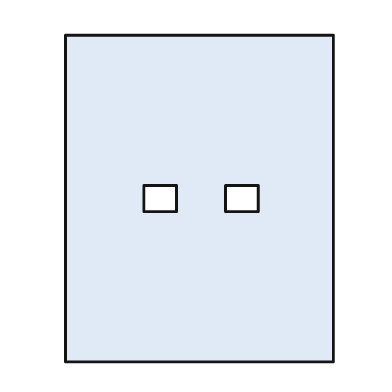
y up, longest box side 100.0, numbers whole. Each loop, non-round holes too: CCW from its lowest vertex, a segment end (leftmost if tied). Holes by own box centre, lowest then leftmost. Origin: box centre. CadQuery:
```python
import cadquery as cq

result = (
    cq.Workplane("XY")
    .moveTo(-41.0, -50.0)
    .lineTo(41.0, -50.0)
    .lineTo(41.0, 50.0)
    .lineTo(-41.0, 50.0)
    .close()
    .moveTo(-17.0, -4.0)
    .lineTo(-7.0, -4.0)
    .lineTo(-7.0, 4.0)
    .lineTo(-17.0, 4.0)
    .close()
    .moveTo(8.0, -4.0)
    .lineTo(18.0, -4.0)
    .lineTo(18.0, 4.0)
    .lineTo(8.0, 4.0)
    .close()
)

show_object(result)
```